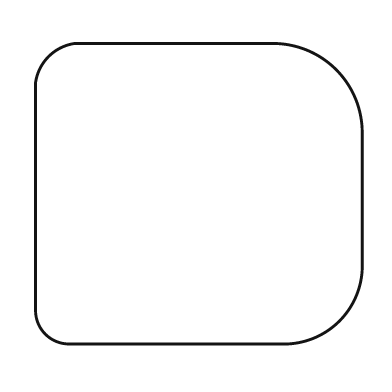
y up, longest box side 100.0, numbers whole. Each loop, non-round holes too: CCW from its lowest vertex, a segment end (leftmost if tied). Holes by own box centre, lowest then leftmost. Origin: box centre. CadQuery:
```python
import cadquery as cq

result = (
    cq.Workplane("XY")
    .moveTo(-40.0, -46.0)
    .lineTo(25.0, -46.0)
    .threePointArc((43.0, -39.0), (50.0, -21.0))
    .lineTo(50.0, 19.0)
    .threePointArc((42.0, 38.0), (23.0, 46.0))
    .lineTo(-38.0, 46.0)
    .threePointArc((-46.0, 42.0), (-50.0, 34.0))
    .lineTo(-50.0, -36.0)
    .threePointArc((-47.0, -43.0), (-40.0, -46.0))
    .close()
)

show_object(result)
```